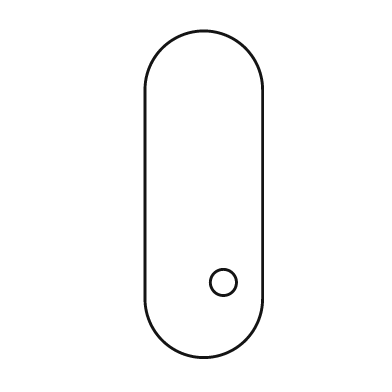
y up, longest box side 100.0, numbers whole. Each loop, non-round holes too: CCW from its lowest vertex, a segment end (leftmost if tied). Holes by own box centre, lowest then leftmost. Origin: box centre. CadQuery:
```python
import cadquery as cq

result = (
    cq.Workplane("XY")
    .moveTo(-18.0, -32.0)
    .threePointArc((0.0, -50.0), (18.0, -32.0))
    .lineTo(18.0, 32.0)
    .threePointArc((0.0, 50.0), (-18.0, 32.0))
    .close()
    .moveTo(6.0, -27.0)
    .circle(4.0)
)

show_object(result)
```